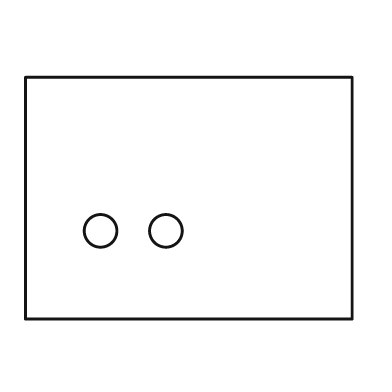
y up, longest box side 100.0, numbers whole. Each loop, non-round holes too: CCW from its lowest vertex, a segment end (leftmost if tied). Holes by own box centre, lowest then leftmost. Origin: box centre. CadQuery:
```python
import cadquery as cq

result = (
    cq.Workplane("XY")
    .moveTo(-50.0, -37.0)
    .lineTo(50.0, -37.0)
    .lineTo(50.0, 37.0)
    .lineTo(-50.0, 37.0)
    .close()
    .moveTo(-27.0, -10.0)
    .circle(5.0)
    .moveTo(-7.0, -10.0)
    .circle(5.0)
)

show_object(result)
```